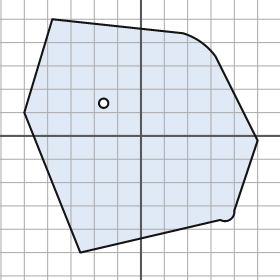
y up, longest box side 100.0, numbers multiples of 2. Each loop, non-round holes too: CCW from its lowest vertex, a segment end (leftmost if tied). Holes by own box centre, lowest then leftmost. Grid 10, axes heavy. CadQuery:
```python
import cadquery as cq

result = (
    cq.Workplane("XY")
    .moveTo(-26.0, -50.0)
    .lineTo(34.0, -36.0)
    .threePointArc((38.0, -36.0), (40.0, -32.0))
    .lineTo(50.0, -2.0)
    .lineTo(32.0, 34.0)
    .threePointArc((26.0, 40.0), (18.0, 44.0))
    .lineTo(-38.0, 50.0)
    .lineTo(-50.0, 10.0)
    .close()
    .moveTo(-16.0, 14.0)
    .circle(2.0)
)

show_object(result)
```